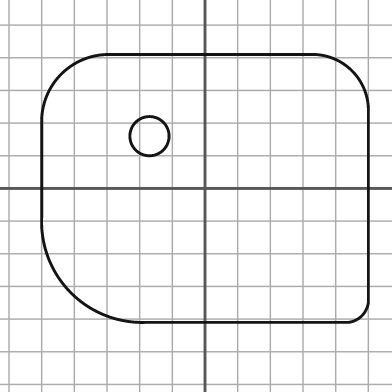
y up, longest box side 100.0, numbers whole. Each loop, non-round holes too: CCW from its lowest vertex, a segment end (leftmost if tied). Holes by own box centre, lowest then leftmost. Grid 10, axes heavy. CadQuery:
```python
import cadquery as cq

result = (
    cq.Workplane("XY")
    .moveTo(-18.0, -41.0)
    .lineTo(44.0, -41.0)
    .threePointArc((48.0, -39.0), (50.0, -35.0))
    .lineTo(50.0, 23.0)
    .threePointArc((45.0, 36.0), (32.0, 41.0))
    .lineTo(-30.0, 41.0)
    .threePointArc((-44.0, 35.0), (-50.0, 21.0))
    .lineTo(-50.0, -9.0)
    .threePointArc((-41.0, -32.0), (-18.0, -41.0))
    .close()
    .moveTo(-17.0, 16.0)
    .circle(6.0)
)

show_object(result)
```